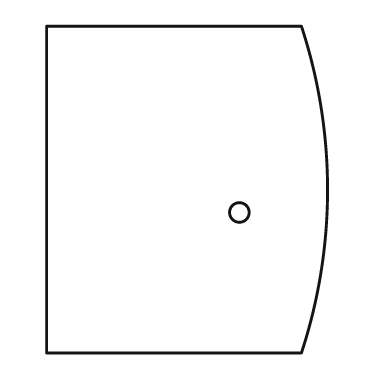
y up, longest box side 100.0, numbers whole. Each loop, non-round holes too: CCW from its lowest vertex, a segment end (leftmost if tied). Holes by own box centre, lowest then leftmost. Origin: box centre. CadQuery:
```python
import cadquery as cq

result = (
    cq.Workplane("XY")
    .moveTo(-43.0, -50.0)
    .lineTo(35.0, -50.0)
    .threePointArc((43.0, 0.0), (35.0, 50.0))
    .lineTo(-43.0, 50.0)
    .close()
    .moveTo(16.0, -7.0)
    .circle(3.0)
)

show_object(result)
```